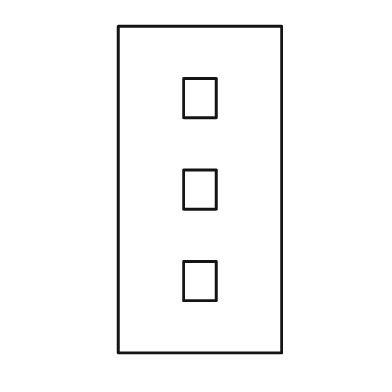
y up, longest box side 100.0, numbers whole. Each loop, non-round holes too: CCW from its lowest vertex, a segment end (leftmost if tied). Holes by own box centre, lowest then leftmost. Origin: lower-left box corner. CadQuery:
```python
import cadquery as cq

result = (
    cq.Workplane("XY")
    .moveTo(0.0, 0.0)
    .lineTo(50.0, 0.0)
    .lineTo(50.0, 100.0)
    .lineTo(0.0, 100.0)
    .close()
    .moveTo(20.0, 16.0)
    .lineTo(30.0, 16.0)
    .lineTo(30.0, 28.0)
    .lineTo(20.0, 28.0)
    .close()
    .moveTo(20.0, 44.0)
    .lineTo(30.0, 44.0)
    .lineTo(30.0, 56.0)
    .lineTo(20.0, 56.0)
    .close()
    .moveTo(20.0, 72.0)
    .lineTo(30.0, 72.0)
    .lineTo(30.0, 84.0)
    .lineTo(20.0, 84.0)
    .close()
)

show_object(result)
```